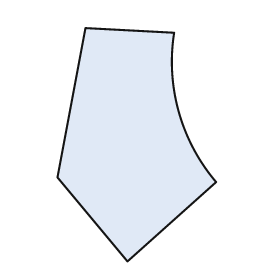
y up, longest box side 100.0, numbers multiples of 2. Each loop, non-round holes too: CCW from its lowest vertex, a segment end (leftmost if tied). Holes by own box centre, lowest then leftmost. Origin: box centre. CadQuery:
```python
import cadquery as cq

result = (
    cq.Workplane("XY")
    .moveTo(-4.0, -50.0)
    .lineTo(34.0, -16.0)
    .threePointArc((18.0, 14.0), (16.0, 48.0))
    .lineTo(-22.0, 50.0)
    .lineTo(-34.0, -14.0)
    .close()
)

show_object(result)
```